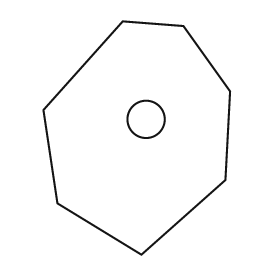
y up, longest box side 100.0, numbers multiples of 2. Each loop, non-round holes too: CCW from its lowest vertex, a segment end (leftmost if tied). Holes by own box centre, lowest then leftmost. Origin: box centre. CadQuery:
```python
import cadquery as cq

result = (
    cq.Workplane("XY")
    .moveTo(2.0, -50.0)
    .lineTo(38.0, -18.0)
    .lineTo(40.0, 20.0)
    .lineTo(20.0, 48.0)
    .lineTo(-6.0, 50.0)
    .lineTo(-40.0, 12.0)
    .lineTo(-34.0, -28.0)
    .close()
    .moveTo(4.0, 8.0)
    .circle(8.0)
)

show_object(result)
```